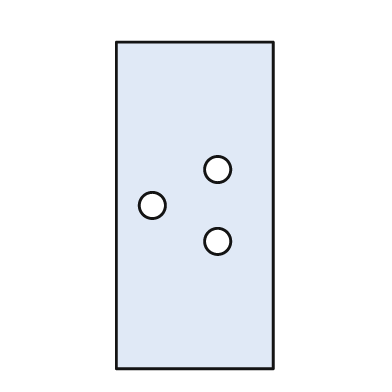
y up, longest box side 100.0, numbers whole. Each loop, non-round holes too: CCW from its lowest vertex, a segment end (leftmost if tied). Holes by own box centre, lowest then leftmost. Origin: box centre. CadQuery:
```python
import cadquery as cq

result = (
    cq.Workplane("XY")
    .moveTo(-24.0, -50.0)
    .lineTo(24.0, -50.0)
    .lineTo(24.0, 50.0)
    .lineTo(-24.0, 50.0)
    .close()
    .moveTo(7.0, -11.0)
    .circle(4.0)
    .moveTo(-13.0, 0.0)
    .circle(4.0)
    .moveTo(7.0, 11.0)
    .circle(4.0)
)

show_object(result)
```